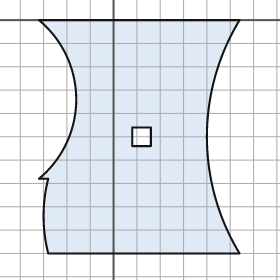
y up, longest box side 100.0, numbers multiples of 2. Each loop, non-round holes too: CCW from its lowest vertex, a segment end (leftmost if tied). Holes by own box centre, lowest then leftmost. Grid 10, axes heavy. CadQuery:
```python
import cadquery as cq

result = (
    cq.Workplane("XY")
    .moveTo(-28.0, -100.0)
    .lineTo(54.0, -100.0)
    .threePointArc((40.0, -50.0), (54.0, 0.0))
    .lineTo(-32.0, 0.0)
    .threePointArc((-16.0, -34.0), (-32.0, -68.0))
    .lineTo(-28.0, -68.0)
    .threePointArc((-30.0, -84.0), (-28.0, -100.0))
    .close()
    .moveTo(8.0, -54.0)
    .lineTo(16.0, -54.0)
    .lineTo(16.0, -46.0)
    .lineTo(8.0, -46.0)
    .close()
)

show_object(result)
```